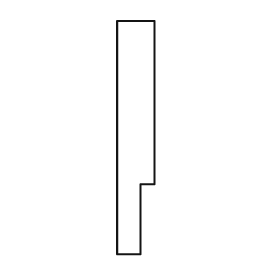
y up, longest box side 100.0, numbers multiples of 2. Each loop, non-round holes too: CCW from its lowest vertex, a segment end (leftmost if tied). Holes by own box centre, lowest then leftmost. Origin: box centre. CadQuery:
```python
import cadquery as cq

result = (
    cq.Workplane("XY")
    .moveTo(-8.0, -50.0)
    .lineTo(2.0, -50.0)
    .lineTo(2.0, -20.0)
    .lineTo(8.0, -20.0)
    .lineTo(8.0, 50.0)
    .lineTo(-8.0, 50.0)
    .close()
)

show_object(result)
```